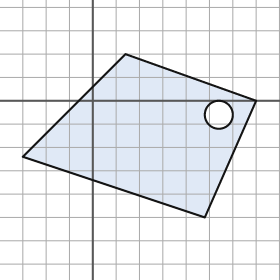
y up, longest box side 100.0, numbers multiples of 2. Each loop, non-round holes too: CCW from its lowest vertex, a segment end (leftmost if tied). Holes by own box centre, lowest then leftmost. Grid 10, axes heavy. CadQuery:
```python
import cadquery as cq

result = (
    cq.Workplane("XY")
    .moveTo(48.0, -50.0)
    .lineTo(70.0, 0.0)
    .lineTo(14.0, 20.0)
    .lineTo(-30.0, -24.0)
    .close()
    .moveTo(54.0, -6.0)
    .circle(6.0)
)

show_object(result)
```